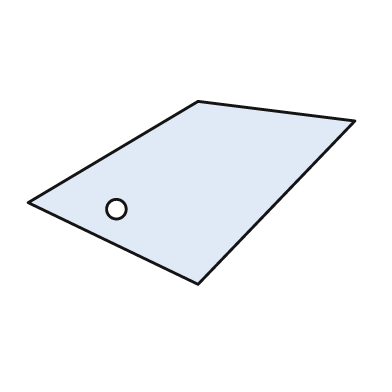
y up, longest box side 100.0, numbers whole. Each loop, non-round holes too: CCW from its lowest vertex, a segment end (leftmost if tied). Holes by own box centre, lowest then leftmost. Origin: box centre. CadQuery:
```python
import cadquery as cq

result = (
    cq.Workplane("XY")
    .moveTo(2.0, -28.0)
    .lineTo(50.0, 22.0)
    .lineTo(2.0, 28.0)
    .lineTo(-50.0, -3.0)
    .close()
    .moveTo(-23.0, -5.0)
    .circle(3.0)
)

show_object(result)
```